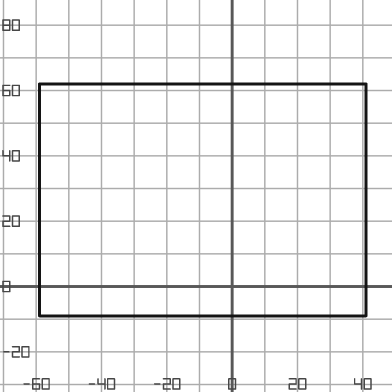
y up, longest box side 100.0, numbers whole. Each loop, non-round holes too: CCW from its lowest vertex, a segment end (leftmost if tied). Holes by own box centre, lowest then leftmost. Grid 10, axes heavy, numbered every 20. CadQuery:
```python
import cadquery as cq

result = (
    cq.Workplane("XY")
    .moveTo(-59.0, -9.0)
    .lineTo(41.0, -9.0)
    .lineTo(41.0, 62.0)
    .lineTo(-59.0, 62.0)
    .close()
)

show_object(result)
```